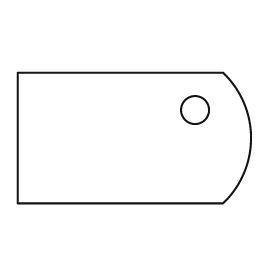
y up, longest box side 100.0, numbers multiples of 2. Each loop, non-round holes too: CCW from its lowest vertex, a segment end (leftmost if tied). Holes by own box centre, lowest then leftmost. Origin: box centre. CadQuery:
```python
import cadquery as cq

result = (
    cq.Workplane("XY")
    .moveTo(-50.0, -28.0)
    .lineTo(38.0, -28.0)
    .threePointArc((50.0, 0.0), (38.0, 28.0))
    .lineTo(-50.0, 28.0)
    .close()
    .moveTo(26.0, 12.0)
    .circle(6.0)
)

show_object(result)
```